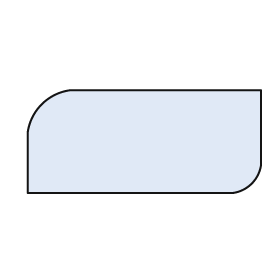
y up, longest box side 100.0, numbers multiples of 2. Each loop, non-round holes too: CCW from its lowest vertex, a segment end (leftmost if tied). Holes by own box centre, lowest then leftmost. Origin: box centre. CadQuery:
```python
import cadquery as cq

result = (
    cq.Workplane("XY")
    .moveTo(-50.0, -22.0)
    .lineTo(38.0, -22.0)
    .threePointArc((46.0, -18.0), (50.0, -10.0))
    .lineTo(50.0, 22.0)
    .lineTo(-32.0, 22.0)
    .threePointArc((-44.0, 16.0), (-50.0, 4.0))
    .close()
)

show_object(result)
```